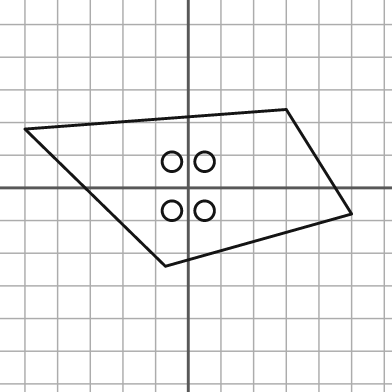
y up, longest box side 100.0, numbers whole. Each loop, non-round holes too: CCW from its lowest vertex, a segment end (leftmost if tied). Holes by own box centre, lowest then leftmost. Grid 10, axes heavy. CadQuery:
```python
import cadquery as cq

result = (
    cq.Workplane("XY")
    .moveTo(-7.0, -24.0)
    .lineTo(50.0, -8.0)
    .lineTo(30.0, 24.0)
    .lineTo(-50.0, 18.0)
    .close()
    .moveTo(-5.0, -7.0)
    .circle(3.0)
    .moveTo(5.0, -7.0)
    .circle(3.0)
    .moveTo(-5.0, 8.0)
    .circle(3.0)
    .moveTo(5.0, 8.0)
    .circle(3.0)
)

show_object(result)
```